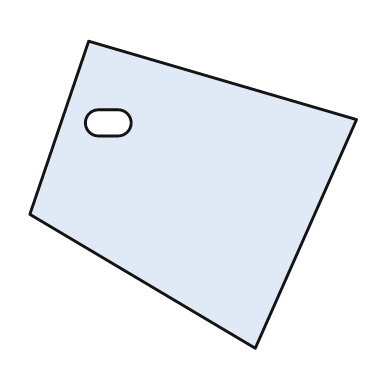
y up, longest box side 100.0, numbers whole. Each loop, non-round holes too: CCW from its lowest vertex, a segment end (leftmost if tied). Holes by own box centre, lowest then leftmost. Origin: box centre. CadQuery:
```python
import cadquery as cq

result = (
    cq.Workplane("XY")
    .moveTo(19.0, -47.0)
    .lineTo(50.0, 23.0)
    .lineTo(-32.0, 47.0)
    .lineTo(-50.0, -6.0)
    .close()
    .moveTo(-29.0, 18.0)
    .lineTo(-23.0, 18.0)
    .threePointArc((-19.0, 22.0), (-23.0, 26.0))
    .lineTo(-29.0, 26.0)
    .threePointArc((-33.0, 22.0), (-29.0, 18.0))
    .close()
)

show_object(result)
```